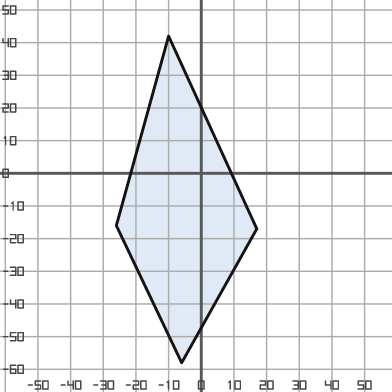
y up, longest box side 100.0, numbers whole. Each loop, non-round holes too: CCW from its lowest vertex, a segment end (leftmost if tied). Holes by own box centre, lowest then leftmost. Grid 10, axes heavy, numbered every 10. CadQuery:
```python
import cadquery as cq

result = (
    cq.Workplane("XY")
    .moveTo(-6.0, -58.0)
    .lineTo(17.0, -17.0)
    .lineTo(-10.0, 42.0)
    .lineTo(-26.0, -16.0)
    .close()
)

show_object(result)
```